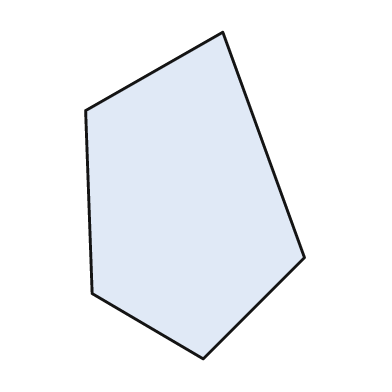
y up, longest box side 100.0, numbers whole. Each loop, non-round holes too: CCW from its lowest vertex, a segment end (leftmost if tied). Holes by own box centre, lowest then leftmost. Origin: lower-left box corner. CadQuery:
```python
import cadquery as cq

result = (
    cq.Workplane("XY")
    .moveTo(36.0, 0.0)
    .lineTo(67.0, 31.0)
    .lineTo(42.0, 100.0)
    .lineTo(0.0, 76.0)
    .lineTo(2.0, 20.0)
    .close()
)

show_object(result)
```